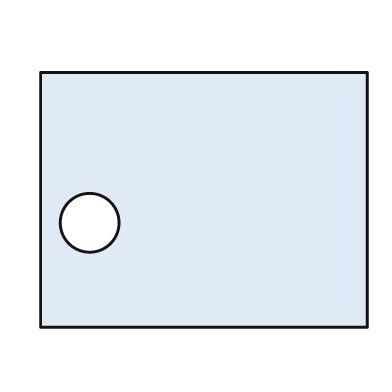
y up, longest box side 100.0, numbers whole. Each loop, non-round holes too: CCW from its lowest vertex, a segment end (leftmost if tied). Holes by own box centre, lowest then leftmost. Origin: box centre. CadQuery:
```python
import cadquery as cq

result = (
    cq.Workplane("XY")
    .moveTo(-50.0, -39.0)
    .lineTo(50.0, -39.0)
    .lineTo(50.0, 39.0)
    .lineTo(-50.0, 39.0)
    .close()
    .moveTo(-35.0, -7.0)
    .circle(9.0)
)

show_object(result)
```